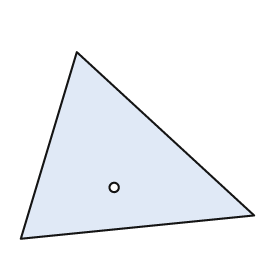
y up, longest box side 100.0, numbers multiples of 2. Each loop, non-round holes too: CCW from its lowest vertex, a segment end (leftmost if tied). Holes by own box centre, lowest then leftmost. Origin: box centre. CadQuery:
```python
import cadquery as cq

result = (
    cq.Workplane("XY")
    .moveTo(-50.0, -40.0)
    .lineTo(50.0, -30.0)
    .lineTo(-26.0, 40.0)
    .close()
    .moveTo(-10.0, -18.0)
    .circle(2.0)
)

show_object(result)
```